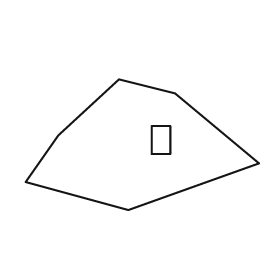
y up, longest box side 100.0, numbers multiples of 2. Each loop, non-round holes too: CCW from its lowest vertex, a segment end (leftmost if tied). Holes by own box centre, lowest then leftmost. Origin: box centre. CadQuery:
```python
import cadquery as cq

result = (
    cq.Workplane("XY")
    .moveTo(-6.0, -28.0)
    .lineTo(50.0, -8.0)
    .lineTo(14.0, 22.0)
    .lineTo(-10.0, 28.0)
    .lineTo(-36.0, 4.0)
    .lineTo(-50.0, -16.0)
    .close()
    .moveTo(4.0, -4.0)
    .lineTo(12.0, -4.0)
    .lineTo(12.0, 8.0)
    .lineTo(4.0, 8.0)
    .close()
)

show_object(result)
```